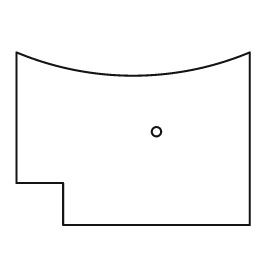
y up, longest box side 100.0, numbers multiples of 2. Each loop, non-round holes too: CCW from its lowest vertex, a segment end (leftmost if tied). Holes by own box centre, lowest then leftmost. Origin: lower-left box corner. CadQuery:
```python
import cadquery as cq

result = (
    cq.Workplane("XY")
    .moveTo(20.0, 0.0)
    .lineTo(100.0, 0.0)
    .lineTo(100.0, 74.0)
    .threePointArc((50.0, 64.0), (0.0, 74.0))
    .lineTo(0.0, 18.0)
    .lineTo(20.0, 18.0)
    .close()
    .moveTo(60.0, 40.0)
    .circle(2.0)
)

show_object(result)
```